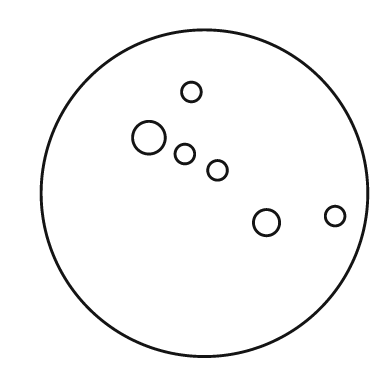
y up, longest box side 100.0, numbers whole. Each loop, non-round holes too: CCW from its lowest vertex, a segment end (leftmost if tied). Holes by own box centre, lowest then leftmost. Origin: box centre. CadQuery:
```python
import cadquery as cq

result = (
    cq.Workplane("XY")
    .moveTo(0.0, 0.0)
    .circle(50.0)
    .moveTo(19.0, -9.0)
    .circle(4.0)
    .moveTo(40.0, -7.0)
    .circle(3.0)
    .moveTo(4.0, 7.0)
    .circle(3.0)
    .moveTo(-6.0, 12.0)
    .circle(3.0)
    .moveTo(-17.0, 17.0)
    .circle(5.0)
    .moveTo(-4.0, 31.0)
    .circle(3.0)
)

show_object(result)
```